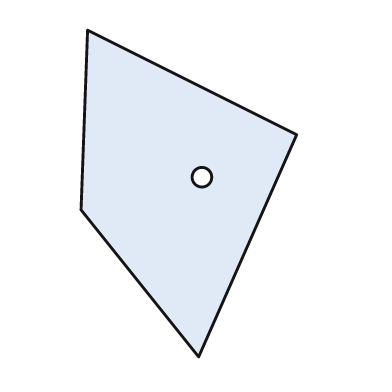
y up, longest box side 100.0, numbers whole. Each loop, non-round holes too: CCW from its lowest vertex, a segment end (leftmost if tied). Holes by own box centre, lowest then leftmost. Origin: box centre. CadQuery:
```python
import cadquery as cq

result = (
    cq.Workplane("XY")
    .moveTo(3.0, -50.0)
    .lineTo(33.0, 18.0)
    .lineTo(-31.0, 50.0)
    .lineTo(-33.0, -5.0)
    .close()
    .moveTo(4.0, 5.0)
    .circle(3.0)
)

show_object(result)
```